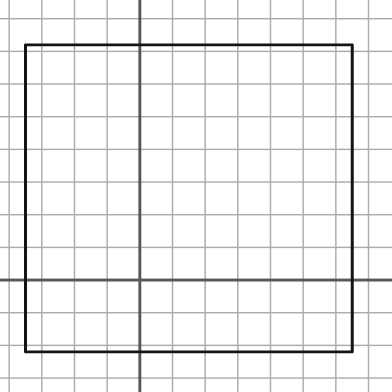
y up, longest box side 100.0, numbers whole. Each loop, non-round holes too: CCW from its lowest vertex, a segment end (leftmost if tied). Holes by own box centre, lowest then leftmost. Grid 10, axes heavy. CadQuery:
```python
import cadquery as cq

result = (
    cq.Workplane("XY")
    .moveTo(-35.0, -22.0)
    .lineTo(65.0, -22.0)
    .lineTo(65.0, 72.0)
    .lineTo(-35.0, 72.0)
    .close()
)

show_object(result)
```